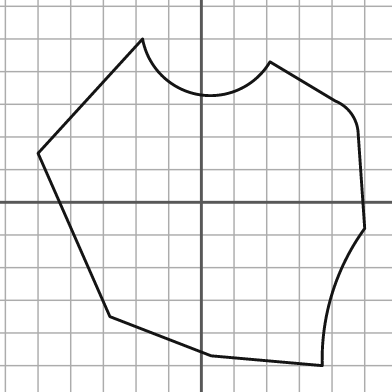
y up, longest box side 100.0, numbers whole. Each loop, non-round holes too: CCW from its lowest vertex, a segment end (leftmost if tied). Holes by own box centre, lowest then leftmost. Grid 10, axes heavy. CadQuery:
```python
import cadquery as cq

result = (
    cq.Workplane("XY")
    .moveTo(37.0, -50.0)
    .threePointArc((40.0, -28.0), (50.0, -8.0))
    .lineTo(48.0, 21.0)
    .threePointArc((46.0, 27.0), (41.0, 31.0))
    .lineTo(21.0, 43.0)
    .threePointArc((-1.0, 33.0), (-18.0, 50.0))
    .lineTo(-50.0, 15.0)
    .lineTo(-28.0, -35.0)
    .lineTo(3.0, -47.0)
    .close()
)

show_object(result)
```